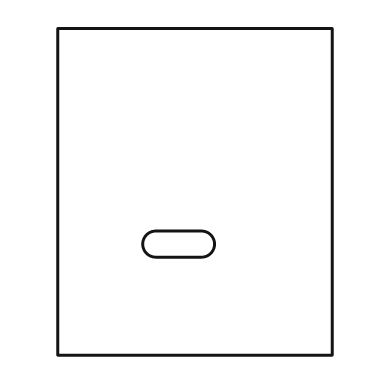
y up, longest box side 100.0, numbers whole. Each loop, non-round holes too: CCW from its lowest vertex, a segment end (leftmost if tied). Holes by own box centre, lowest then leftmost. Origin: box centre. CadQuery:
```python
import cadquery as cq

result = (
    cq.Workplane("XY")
    .moveTo(-42.0, -50.0)
    .lineTo(42.0, -50.0)
    .lineTo(42.0, 50.0)
    .lineTo(-42.0, 50.0)
    .close()
    .moveTo(-12.0, -20.0)
    .lineTo(2.0, -20.0)
    .threePointArc((6.0, -16.0), (2.0, -12.0))
    .lineTo(-12.0, -12.0)
    .threePointArc((-16.0, -16.0), (-12.0, -20.0))
    .close()
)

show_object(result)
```